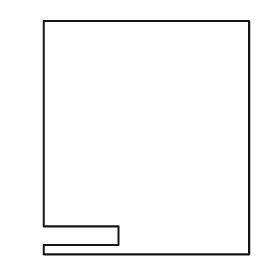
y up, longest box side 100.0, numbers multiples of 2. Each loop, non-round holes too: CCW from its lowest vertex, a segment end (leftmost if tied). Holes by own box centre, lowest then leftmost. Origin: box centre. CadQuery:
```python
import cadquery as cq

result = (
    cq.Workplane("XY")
    .moveTo(-44.0, -50.0)
    .lineTo(44.0, -50.0)
    .lineTo(44.0, 50.0)
    .lineTo(-44.0, 50.0)
    .lineTo(-44.0, -38.0)
    .lineTo(-12.0, -38.0)
    .lineTo(-12.0, -46.0)
    .lineTo(-44.0, -46.0)
    .close()
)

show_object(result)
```